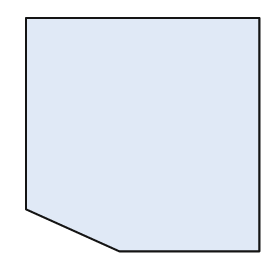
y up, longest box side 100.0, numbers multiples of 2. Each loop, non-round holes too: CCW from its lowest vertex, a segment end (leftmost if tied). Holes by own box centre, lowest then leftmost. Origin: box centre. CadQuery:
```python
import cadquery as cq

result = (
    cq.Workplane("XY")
    .moveTo(-10.0, -50.0)
    .lineTo(50.0, -50.0)
    .lineTo(50.0, 50.0)
    .lineTo(-50.0, 50.0)
    .lineTo(-50.0, -32.0)
    .close()
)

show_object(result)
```